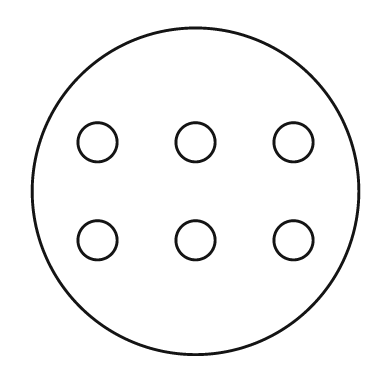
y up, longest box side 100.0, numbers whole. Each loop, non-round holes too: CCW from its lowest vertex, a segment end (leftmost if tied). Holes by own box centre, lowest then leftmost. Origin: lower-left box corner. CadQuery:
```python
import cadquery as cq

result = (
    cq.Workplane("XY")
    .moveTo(50.0, 50.0)
    .circle(50.0)
    .moveTo(20.0, 35.0)
    .circle(6.0)
    .moveTo(50.0, 35.0)
    .circle(6.0)
    .moveTo(80.0, 35.0)
    .circle(6.0)
    .moveTo(20.0, 65.0)
    .circle(6.0)
    .moveTo(50.0, 65.0)
    .circle(6.0)
    .moveTo(80.0, 65.0)
    .circle(6.0)
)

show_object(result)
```